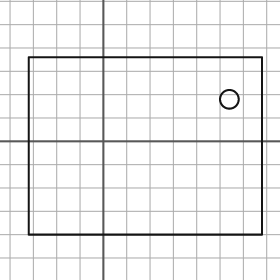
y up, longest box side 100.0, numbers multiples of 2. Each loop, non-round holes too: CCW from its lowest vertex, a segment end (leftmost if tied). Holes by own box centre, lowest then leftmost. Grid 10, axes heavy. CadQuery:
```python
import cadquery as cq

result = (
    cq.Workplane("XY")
    .moveTo(-32.0, -40.0)
    .lineTo(68.0, -40.0)
    .lineTo(68.0, 36.0)
    .lineTo(-32.0, 36.0)
    .close()
    .moveTo(54.0, 18.0)
    .circle(4.0)
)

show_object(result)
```